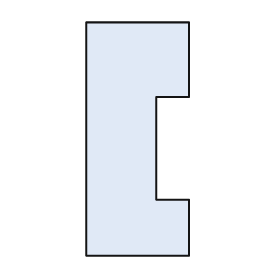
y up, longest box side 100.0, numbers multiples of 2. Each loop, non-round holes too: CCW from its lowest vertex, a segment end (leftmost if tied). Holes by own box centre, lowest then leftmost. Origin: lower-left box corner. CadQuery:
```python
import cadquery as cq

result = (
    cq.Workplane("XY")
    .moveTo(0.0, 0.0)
    .lineTo(44.0, 0.0)
    .lineTo(44.0, 24.0)
    .lineTo(30.0, 24.0)
    .lineTo(30.0, 68.0)
    .lineTo(44.0, 68.0)
    .lineTo(44.0, 100.0)
    .lineTo(0.0, 100.0)
    .close()
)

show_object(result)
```